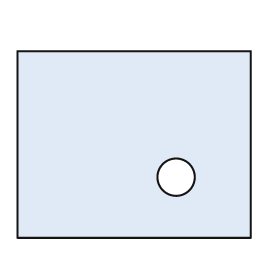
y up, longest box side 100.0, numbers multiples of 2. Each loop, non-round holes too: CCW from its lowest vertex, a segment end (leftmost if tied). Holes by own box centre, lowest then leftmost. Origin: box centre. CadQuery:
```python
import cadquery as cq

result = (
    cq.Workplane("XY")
    .moveTo(-50.0, -40.0)
    .lineTo(50.0, -40.0)
    .lineTo(50.0, 40.0)
    .lineTo(-50.0, 40.0)
    .close()
    .moveTo(18.0, -14.0)
    .circle(8.0)
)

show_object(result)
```